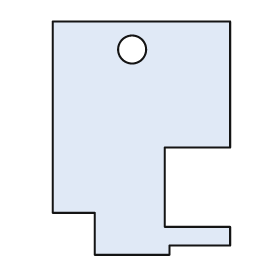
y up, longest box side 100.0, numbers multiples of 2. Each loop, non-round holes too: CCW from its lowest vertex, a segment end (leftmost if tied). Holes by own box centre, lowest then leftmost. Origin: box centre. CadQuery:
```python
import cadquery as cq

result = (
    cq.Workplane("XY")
    .moveTo(-20.0, -50.0)
    .lineTo(12.0, -50.0)
    .lineTo(12.0, -46.0)
    .lineTo(38.0, -46.0)
    .lineTo(38.0, -38.0)
    .lineTo(10.0, -38.0)
    .lineTo(10.0, -4.0)
    .lineTo(38.0, -4.0)
    .lineTo(38.0, 50.0)
    .lineTo(-38.0, 50.0)
    .lineTo(-38.0, -32.0)
    .lineTo(-20.0, -32.0)
    .close()
    .moveTo(-4.0, 38.0)
    .circle(6.0)
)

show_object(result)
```